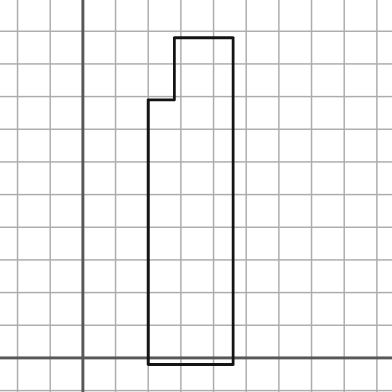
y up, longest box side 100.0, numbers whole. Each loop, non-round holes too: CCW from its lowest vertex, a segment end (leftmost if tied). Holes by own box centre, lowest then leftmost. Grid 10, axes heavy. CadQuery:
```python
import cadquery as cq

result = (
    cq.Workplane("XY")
    .moveTo(20.0, -2.0)
    .lineTo(46.0, -2.0)
    .lineTo(46.0, 98.0)
    .lineTo(28.0, 98.0)
    .lineTo(28.0, 79.0)
    .lineTo(20.0, 79.0)
    .close()
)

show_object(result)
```